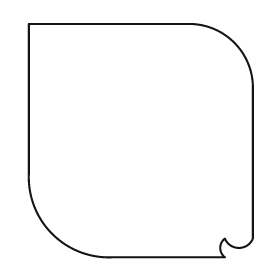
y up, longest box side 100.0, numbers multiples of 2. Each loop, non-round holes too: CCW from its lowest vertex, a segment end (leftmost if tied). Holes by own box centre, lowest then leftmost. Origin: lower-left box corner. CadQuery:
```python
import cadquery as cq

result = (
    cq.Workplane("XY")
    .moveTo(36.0, 0.0)
    .lineTo(84.0, 0.0)
    .threePointArc((82.0, 4.0), (84.0, 8.0))
    .threePointArc((90.0, 4.0), (96.0, 8.0))
    .lineTo(96.0, 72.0)
    .threePointArc((88.0, 92.0), (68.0, 100.0))
    .lineTo(0.0, 100.0)
    .lineTo(0.0, 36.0)
    .threePointArc((10.0, 10.0), (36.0, 0.0))
    .close()
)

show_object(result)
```